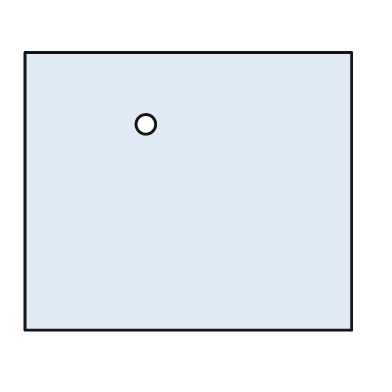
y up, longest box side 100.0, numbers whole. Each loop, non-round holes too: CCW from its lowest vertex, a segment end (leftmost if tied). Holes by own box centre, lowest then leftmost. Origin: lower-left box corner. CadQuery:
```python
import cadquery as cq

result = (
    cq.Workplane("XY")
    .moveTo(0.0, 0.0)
    .lineTo(100.0, 0.0)
    .lineTo(100.0, 85.0)
    .lineTo(0.0, 85.0)
    .close()
    .moveTo(37.0, 63.0)
    .circle(3.0)
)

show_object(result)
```